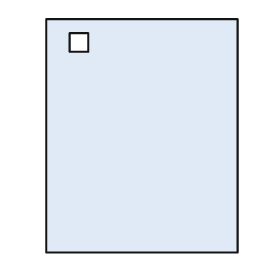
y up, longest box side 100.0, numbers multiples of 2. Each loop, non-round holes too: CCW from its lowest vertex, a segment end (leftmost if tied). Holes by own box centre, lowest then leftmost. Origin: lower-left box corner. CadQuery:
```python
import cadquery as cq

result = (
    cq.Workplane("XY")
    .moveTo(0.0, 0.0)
    .lineTo(82.0, 0.0)
    .lineTo(82.0, 100.0)
    .lineTo(0.0, 100.0)
    .close()
    .moveTo(10.0, 86.0)
    .lineTo(18.0, 86.0)
    .lineTo(18.0, 94.0)
    .lineTo(10.0, 94.0)
    .close()
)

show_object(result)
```